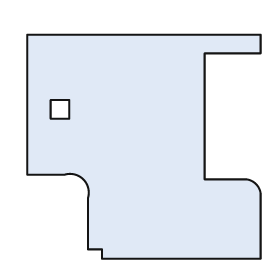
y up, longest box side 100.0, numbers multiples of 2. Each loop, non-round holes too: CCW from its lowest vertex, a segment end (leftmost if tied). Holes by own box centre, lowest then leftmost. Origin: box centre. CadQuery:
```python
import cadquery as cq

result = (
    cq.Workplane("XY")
    .moveTo(-18.0, -48.0)
    .lineTo(50.0, -48.0)
    .lineTo(50.0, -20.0)
    .threePointArc((48.0, -16.0), (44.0, -14.0))
    .lineTo(26.0, -14.0)
    .lineTo(26.0, 40.0)
    .lineTo(50.0, 40.0)
    .lineTo(50.0, 48.0)
    .lineTo(-50.0, 48.0)
    .lineTo(-50.0, -12.0)
    .lineTo(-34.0, -12.0)
    .threePointArc((-26.0, -14.0), (-24.0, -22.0))
    .lineTo(-24.0, -44.0)
    .lineTo(-18.0, -44.0)
    .close()
    .moveTo(-40.0, 12.0)
    .lineTo(-32.0, 12.0)
    .lineTo(-32.0, 20.0)
    .lineTo(-40.0, 20.0)
    .close()
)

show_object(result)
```